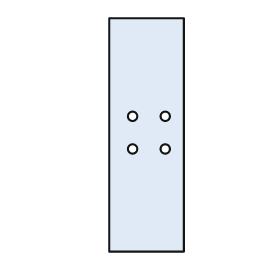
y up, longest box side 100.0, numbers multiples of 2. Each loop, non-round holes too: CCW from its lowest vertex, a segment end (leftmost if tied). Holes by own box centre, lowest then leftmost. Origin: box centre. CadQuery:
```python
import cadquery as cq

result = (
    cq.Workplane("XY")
    .moveTo(-16.0, -50.0)
    .lineTo(16.0, -50.0)
    .lineTo(16.0, 50.0)
    .lineTo(-16.0, 50.0)
    .close()
    .moveTo(-6.0, -6.0)
    .circle(2.0)
    .moveTo(8.0, -6.0)
    .circle(2.0)
    .moveTo(-6.0, 8.0)
    .circle(2.0)
    .moveTo(8.0, 8.0)
    .circle(2.0)
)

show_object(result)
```